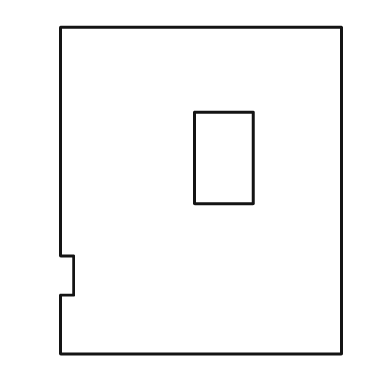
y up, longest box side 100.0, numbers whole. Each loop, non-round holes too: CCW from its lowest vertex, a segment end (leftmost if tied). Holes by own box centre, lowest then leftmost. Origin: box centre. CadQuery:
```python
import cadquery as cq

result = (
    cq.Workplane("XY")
    .moveTo(-43.0, -50.0)
    .lineTo(43.0, -50.0)
    .lineTo(43.0, 50.0)
    .lineTo(-43.0, 50.0)
    .lineTo(-43.0, -20.0)
    .lineTo(-39.0, -20.0)
    .lineTo(-39.0, -32.0)
    .lineTo(-43.0, -32.0)
    .close()
    .moveTo(-2.0, -4.0)
    .lineTo(16.0, -4.0)
    .lineTo(16.0, 24.0)
    .lineTo(-2.0, 24.0)
    .close()
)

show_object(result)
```